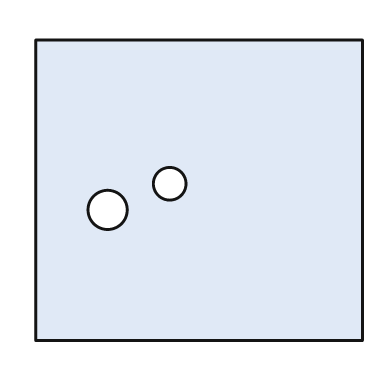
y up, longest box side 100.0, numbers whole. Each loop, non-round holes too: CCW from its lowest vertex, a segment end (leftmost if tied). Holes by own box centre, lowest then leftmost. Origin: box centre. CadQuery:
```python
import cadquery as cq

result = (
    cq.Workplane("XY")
    .moveTo(-50.0, -46.0)
    .lineTo(50.0, -46.0)
    .lineTo(50.0, 46.0)
    .lineTo(-50.0, 46.0)
    .close()
    .moveTo(-28.0, -6.0)
    .circle(6.0)
    .moveTo(-9.0, 2.0)
    .circle(5.0)
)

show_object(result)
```